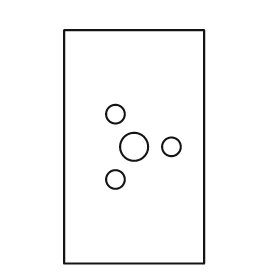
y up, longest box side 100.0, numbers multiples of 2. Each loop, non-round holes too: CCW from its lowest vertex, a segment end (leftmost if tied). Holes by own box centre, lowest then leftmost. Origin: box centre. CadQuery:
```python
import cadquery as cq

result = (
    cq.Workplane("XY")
    .moveTo(-30.0, -50.0)
    .lineTo(30.0, -50.0)
    .lineTo(30.0, 50.0)
    .lineTo(-30.0, 50.0)
    .close()
    .moveTo(-8.0, -14.0)
    .circle(4.0)
    .moveTo(0.0, 0.0)
    .circle(6.0)
    .moveTo(16.0, 0.0)
    .circle(4.0)
    .moveTo(-8.0, 14.0)
    .circle(4.0)
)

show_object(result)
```